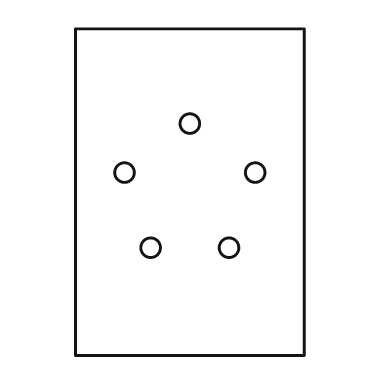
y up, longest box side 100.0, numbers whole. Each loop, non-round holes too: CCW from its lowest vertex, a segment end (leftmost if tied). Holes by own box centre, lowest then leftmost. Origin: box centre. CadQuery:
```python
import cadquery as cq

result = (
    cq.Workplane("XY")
    .moveTo(-35.0, -50.0)
    .lineTo(35.0, -50.0)
    .lineTo(35.0, 50.0)
    .lineTo(-35.0, 50.0)
    .close()
    .moveTo(-12.0, -17.0)
    .circle(3.0)
    .moveTo(12.0, -17.0)
    .circle(3.0)
    .moveTo(-20.0, 6.0)
    .circle(3.0)
    .moveTo(20.0, 6.0)
    .circle(3.0)
    .moveTo(0.0, 21.0)
    .circle(3.0)
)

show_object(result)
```